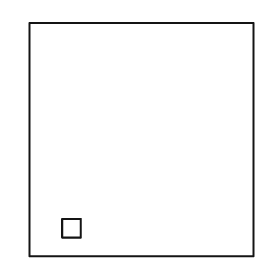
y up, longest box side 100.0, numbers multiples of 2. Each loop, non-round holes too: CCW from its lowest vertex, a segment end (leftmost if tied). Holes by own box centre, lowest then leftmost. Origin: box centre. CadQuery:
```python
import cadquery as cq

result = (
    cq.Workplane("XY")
    .moveTo(-48.0, -50.0)
    .lineTo(48.0, -50.0)
    .lineTo(48.0, 50.0)
    .lineTo(-48.0, 50.0)
    .close()
    .moveTo(-34.0, -42.0)
    .lineTo(-26.0, -42.0)
    .lineTo(-26.0, -34.0)
    .lineTo(-34.0, -34.0)
    .close()
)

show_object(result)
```